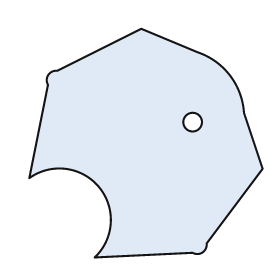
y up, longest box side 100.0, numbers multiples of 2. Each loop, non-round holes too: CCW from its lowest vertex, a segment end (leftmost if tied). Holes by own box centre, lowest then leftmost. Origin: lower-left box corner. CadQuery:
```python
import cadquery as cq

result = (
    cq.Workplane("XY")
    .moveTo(28.0, 0.0)
    .lineTo(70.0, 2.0)
    .threePointArc((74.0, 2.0), (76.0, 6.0))
    .lineTo(100.0, 38.0)
    .lineTo(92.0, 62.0)
    .threePointArc((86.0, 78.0), (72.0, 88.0))
    .lineTo(48.0, 98.0)
    .lineTo(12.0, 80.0)
    .threePointArc((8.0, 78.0), (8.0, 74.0))
    .lineTo(0.0, 34.0)
    .threePointArc((30.0, 30.0), (28.0, 0.0))
    .close()
    .moveTo(70.0, 58.0)
    .circle(4.0)
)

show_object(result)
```